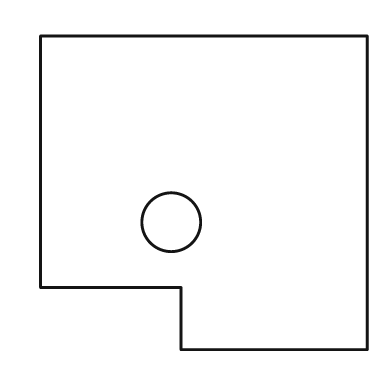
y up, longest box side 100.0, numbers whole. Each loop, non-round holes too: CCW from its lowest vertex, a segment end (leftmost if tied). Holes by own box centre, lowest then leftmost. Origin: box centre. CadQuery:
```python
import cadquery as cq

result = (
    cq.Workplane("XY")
    .moveTo(-7.0, -48.0)
    .lineTo(50.0, -48.0)
    .lineTo(50.0, 48.0)
    .lineTo(-50.0, 48.0)
    .lineTo(-50.0, -29.0)
    .lineTo(-7.0, -29.0)
    .close()
    .moveTo(-10.0, -9.0)
    .circle(9.0)
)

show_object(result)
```